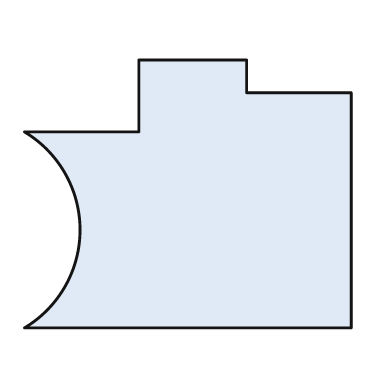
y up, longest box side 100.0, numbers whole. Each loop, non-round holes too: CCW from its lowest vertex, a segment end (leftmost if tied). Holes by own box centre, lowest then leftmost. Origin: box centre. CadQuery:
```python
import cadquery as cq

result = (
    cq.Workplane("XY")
    .moveTo(-50.0, -41.0)
    .lineTo(50.0, -41.0)
    .lineTo(50.0, 31.0)
    .lineTo(18.0, 31.0)
    .lineTo(18.0, 41.0)
    .lineTo(-15.0, 41.0)
    .lineTo(-15.0, 19.0)
    .lineTo(-50.0, 19.0)
    .threePointArc((-33.0, -11.0), (-50.0, -41.0))
    .close()
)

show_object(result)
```